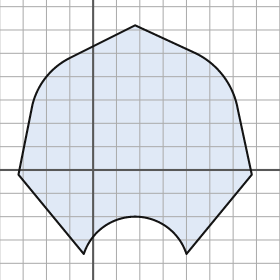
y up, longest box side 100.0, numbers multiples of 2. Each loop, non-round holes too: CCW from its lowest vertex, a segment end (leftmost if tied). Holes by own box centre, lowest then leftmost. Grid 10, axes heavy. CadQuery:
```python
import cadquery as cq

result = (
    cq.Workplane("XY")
    .moveTo(-4.0, -36.0)
    .threePointArc((18.0, -20.0), (40.0, -36.0))
    .lineTo(68.0, -2.0)
    .lineTo(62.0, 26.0)
    .threePointArc((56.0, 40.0), (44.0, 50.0))
    .lineTo(18.0, 62.0)
    .lineTo(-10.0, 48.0)
    .threePointArc((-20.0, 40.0), (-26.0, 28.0))
    .lineTo(-32.0, -2.0)
    .close()
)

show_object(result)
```